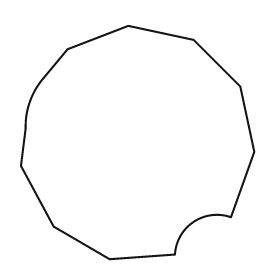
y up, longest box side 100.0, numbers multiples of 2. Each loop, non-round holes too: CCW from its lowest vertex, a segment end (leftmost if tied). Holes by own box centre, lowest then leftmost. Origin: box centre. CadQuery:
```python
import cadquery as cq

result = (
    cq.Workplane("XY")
    .moveTo(-12.0, -50.0)
    .lineTo(16.0, -48.0)
    .threePointArc((24.0, -34.0), (40.0, -32.0))
    .lineTo(50.0, -4.0)
    .lineTo(44.0, 24.0)
    .lineTo(24.0, 44.0)
    .lineTo(-4.0, 50.0)
    .lineTo(-30.0, 40.0)
    .lineTo(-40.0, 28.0)
    .threePointArc((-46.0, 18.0), (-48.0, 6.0))
    .lineTo(-50.0, -10.0)
    .lineTo(-36.0, -36.0)
    .close()
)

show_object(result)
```